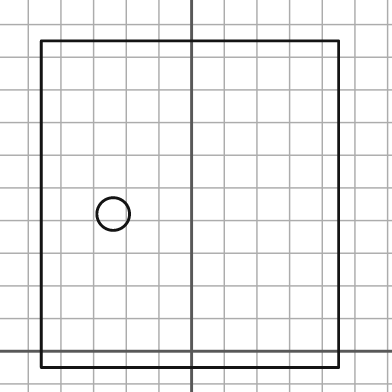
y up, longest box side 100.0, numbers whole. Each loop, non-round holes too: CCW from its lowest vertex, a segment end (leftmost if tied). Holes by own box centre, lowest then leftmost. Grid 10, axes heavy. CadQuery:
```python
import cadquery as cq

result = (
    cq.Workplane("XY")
    .moveTo(-46.0, -5.0)
    .lineTo(45.0, -5.0)
    .lineTo(45.0, 95.0)
    .lineTo(-46.0, 95.0)
    .close()
    .moveTo(-24.0, 42.0)
    .circle(5.0)
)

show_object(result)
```